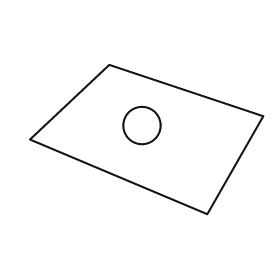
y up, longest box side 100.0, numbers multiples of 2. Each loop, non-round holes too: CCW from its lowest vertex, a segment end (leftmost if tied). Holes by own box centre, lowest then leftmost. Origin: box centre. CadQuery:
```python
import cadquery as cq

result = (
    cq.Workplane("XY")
    .moveTo(26.0, -32.0)
    .lineTo(50.0, 10.0)
    .lineTo(-16.0, 32.0)
    .lineTo(-50.0, 0.0)
    .close()
    .moveTo(-2.0, 6.0)
    .circle(8.0)
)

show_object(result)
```